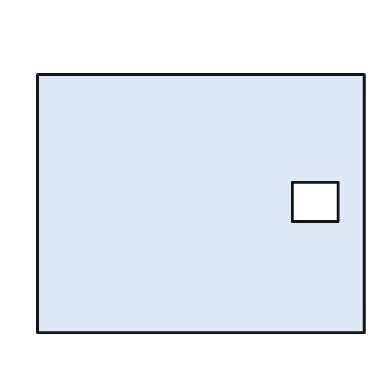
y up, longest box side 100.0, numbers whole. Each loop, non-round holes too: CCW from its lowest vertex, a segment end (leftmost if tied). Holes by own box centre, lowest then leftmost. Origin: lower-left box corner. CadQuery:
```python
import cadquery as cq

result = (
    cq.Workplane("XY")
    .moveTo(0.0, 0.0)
    .lineTo(100.0, 0.0)
    .lineTo(100.0, 79.0)
    .lineTo(0.0, 79.0)
    .close()
    .moveTo(78.0, 34.0)
    .lineTo(92.0, 34.0)
    .lineTo(92.0, 46.0)
    .lineTo(78.0, 46.0)
    .close()
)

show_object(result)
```